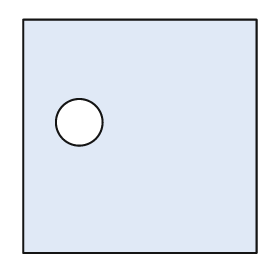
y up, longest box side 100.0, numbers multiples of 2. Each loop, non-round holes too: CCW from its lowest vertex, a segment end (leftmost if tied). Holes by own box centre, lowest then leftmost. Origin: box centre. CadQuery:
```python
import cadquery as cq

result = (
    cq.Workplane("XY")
    .moveTo(-50.0, -50.0)
    .lineTo(50.0, -50.0)
    .lineTo(50.0, 50.0)
    .lineTo(-50.0, 50.0)
    .close()
    .moveTo(-26.0, 6.0)
    .circle(10.0)
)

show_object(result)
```